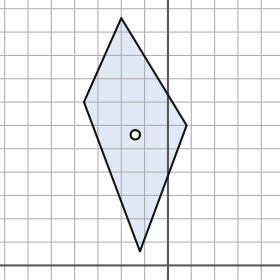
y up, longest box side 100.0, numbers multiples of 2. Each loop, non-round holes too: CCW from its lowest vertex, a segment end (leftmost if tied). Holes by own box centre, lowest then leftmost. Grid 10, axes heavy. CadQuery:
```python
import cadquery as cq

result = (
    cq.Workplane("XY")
    .moveTo(-12.0, 6.0)
    .lineTo(8.0, 60.0)
    .lineTo(-20.0, 106.0)
    .lineTo(-36.0, 70.0)
    .close()
    .moveTo(-14.0, 56.0)
    .circle(2.0)
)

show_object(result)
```